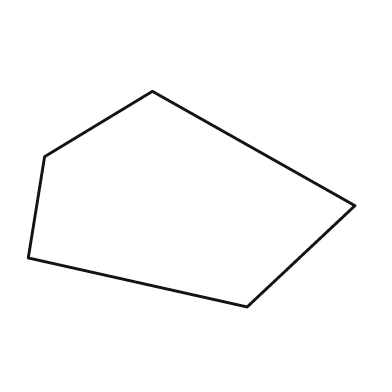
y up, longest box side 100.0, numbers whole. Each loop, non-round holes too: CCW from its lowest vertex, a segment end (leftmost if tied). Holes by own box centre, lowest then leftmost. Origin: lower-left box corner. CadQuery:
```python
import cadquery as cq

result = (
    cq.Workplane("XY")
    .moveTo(67.0, 0.0)
    .lineTo(100.0, 31.0)
    .lineTo(38.0, 66.0)
    .lineTo(5.0, 46.0)
    .lineTo(0.0, 15.0)
    .close()
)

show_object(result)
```